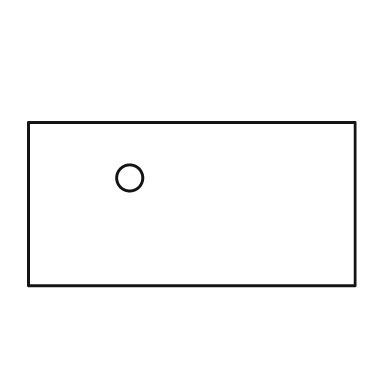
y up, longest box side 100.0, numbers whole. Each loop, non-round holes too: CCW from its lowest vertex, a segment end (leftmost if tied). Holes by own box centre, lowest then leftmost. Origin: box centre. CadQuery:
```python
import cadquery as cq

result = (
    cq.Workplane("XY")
    .moveTo(-50.0, -25.0)
    .lineTo(50.0, -25.0)
    .lineTo(50.0, 25.0)
    .lineTo(-50.0, 25.0)
    .close()
    .moveTo(-19.0, 8.0)
    .circle(4.0)
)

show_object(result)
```